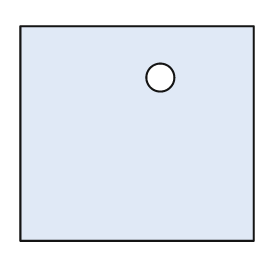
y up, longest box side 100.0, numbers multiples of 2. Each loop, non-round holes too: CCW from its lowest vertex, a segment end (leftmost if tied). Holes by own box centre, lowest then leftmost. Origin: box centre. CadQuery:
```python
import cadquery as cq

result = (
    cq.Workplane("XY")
    .moveTo(-50.0, -46.0)
    .lineTo(50.0, -46.0)
    .lineTo(50.0, 46.0)
    .lineTo(-50.0, 46.0)
    .close()
    .moveTo(10.0, 24.0)
    .circle(6.0)
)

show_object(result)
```